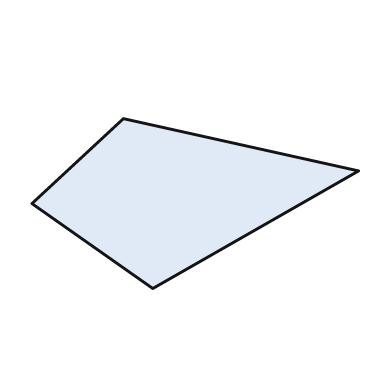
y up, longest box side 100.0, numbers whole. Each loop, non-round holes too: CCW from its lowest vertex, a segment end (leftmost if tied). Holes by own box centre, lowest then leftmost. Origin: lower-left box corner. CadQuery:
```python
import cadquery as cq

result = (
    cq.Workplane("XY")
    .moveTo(37.0, 0.0)
    .lineTo(100.0, 36.0)
    .lineTo(28.0, 52.0)
    .lineTo(0.0, 26.0)
    .close()
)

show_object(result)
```